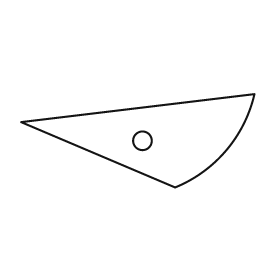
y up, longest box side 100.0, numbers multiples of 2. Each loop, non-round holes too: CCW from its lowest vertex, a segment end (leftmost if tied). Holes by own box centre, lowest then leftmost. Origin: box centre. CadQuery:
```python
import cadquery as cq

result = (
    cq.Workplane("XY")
    .moveTo(16.0, -20.0)
    .threePointArc((38.0, -4.0), (50.0, 20.0))
    .lineTo(-50.0, 8.0)
    .close()
    .moveTo(2.0, 0.0)
    .circle(4.0)
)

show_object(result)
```